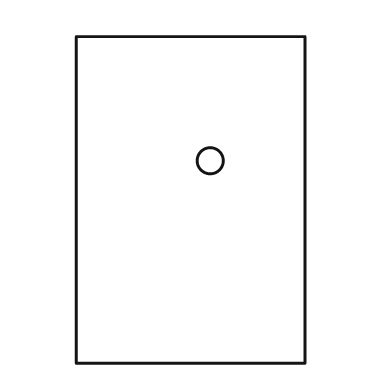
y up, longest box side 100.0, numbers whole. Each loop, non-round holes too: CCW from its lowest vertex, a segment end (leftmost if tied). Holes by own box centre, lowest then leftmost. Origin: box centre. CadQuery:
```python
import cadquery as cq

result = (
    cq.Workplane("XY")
    .moveTo(-35.0, -50.0)
    .lineTo(35.0, -50.0)
    .lineTo(35.0, 50.0)
    .lineTo(-35.0, 50.0)
    .close()
    .moveTo(6.0, 12.0)
    .circle(4.0)
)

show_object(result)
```